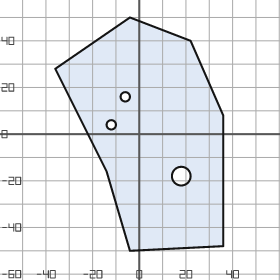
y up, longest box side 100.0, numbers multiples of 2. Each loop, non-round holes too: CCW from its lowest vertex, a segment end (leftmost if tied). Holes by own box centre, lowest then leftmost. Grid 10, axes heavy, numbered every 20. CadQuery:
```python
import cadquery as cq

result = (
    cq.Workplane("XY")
    .moveTo(-4.0, -50.0)
    .lineTo(36.0, -48.0)
    .lineTo(36.0, 8.0)
    .lineTo(22.0, 40.0)
    .lineTo(-4.0, 50.0)
    .lineTo(-36.0, 28.0)
    .lineTo(-14.0, -16.0)
    .close()
    .moveTo(18.0, -18.0)
    .circle(4.0)
    .moveTo(-12.0, 4.0)
    .circle(2.0)
    .moveTo(-6.0, 16.0)
    .circle(2.0)
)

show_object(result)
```